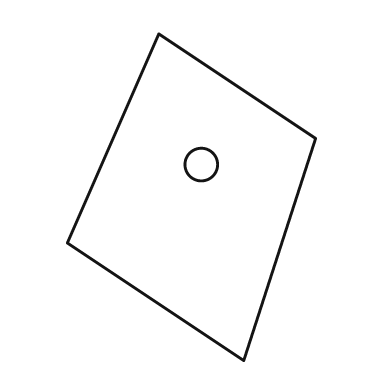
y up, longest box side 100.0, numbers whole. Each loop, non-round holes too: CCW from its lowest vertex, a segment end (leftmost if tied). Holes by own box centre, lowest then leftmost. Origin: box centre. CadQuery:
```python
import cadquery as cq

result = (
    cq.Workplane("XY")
    .moveTo(16.0, -50.0)
    .lineTo(38.0, 18.0)
    .lineTo(-10.0, 50.0)
    .lineTo(-38.0, -14.0)
    .close()
    .moveTo(3.0, 10.0)
    .circle(5.0)
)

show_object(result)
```